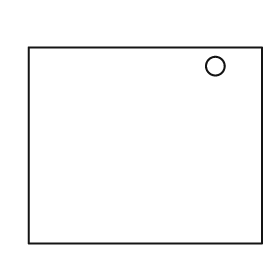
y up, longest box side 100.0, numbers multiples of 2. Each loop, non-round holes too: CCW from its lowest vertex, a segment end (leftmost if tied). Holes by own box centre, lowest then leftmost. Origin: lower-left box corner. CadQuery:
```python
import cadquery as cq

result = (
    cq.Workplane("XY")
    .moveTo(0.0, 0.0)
    .lineTo(100.0, 0.0)
    .lineTo(100.0, 84.0)
    .lineTo(0.0, 84.0)
    .close()
    .moveTo(80.0, 76.0)
    .circle(4.0)
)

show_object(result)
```